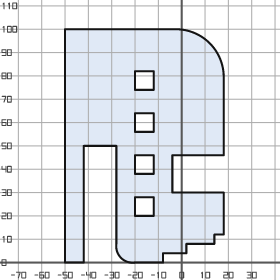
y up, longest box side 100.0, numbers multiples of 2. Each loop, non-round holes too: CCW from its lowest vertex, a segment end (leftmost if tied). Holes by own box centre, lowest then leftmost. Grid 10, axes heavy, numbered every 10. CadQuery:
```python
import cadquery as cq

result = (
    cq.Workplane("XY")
    .moveTo(-50.0, 0.0)
    .lineTo(-42.0, 0.0)
    .lineTo(-42.0, 50.0)
    .lineTo(-28.0, 50.0)
    .lineTo(-28.0, 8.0)
    .threePointArc((-26.0, 2.0), (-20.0, 0.0))
    .lineTo(-8.0, 0.0)
    .lineTo(-8.0, 4.0)
    .lineTo(2.0, 4.0)
    .lineTo(2.0, 8.0)
    .lineTo(14.0, 8.0)
    .lineTo(14.0, 12.0)
    .lineTo(18.0, 12.0)
    .lineTo(18.0, 30.0)
    .lineTo(-4.0, 30.0)
    .lineTo(-4.0, 46.0)
    .lineTo(18.0, 46.0)
    .lineTo(18.0, 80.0)
    .threePointArc((12.0, 94.0), (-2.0, 100.0))
    .lineTo(-50.0, 100.0)
    .close()
    .moveTo(-20.0, 20.0)
    .lineTo(-12.0, 20.0)
    .lineTo(-12.0, 28.0)
    .lineTo(-20.0, 28.0)
    .close()
    .moveTo(-20.0, 38.0)
    .lineTo(-12.0, 38.0)
    .lineTo(-12.0, 46.0)
    .lineTo(-20.0, 46.0)
    .close()
    .moveTo(-20.0, 56.0)
    .lineTo(-12.0, 56.0)
    .lineTo(-12.0, 64.0)
    .lineTo(-20.0, 64.0)
    .close()
    .moveTo(-20.0, 74.0)
    .lineTo(-12.0, 74.0)
    .lineTo(-12.0, 82.0)
    .lineTo(-20.0, 82.0)
    .close()
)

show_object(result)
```